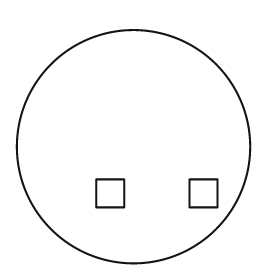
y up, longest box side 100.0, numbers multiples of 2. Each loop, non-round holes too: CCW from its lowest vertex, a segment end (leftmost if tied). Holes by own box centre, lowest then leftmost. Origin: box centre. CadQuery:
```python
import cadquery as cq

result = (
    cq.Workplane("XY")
    .moveTo(0.0, 0.0)
    .circle(50.0)
    .moveTo(-16.0, -26.0)
    .lineTo(-4.0, -26.0)
    .lineTo(-4.0, -14.0)
    .lineTo(-16.0, -14.0)
    .close()
    .moveTo(24.0, -26.0)
    .lineTo(36.0, -26.0)
    .lineTo(36.0, -14.0)
    .lineTo(24.0, -14.0)
    .close()
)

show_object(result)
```